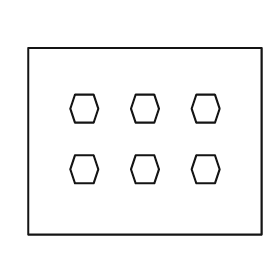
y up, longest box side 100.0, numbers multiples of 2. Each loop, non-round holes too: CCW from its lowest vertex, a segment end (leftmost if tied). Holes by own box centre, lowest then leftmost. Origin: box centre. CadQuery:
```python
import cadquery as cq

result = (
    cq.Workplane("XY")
    .moveTo(-50.0, -40.0)
    .lineTo(50.0, -40.0)
    .lineTo(50.0, 40.0)
    .lineTo(-50.0, 40.0)
    .close()
    .moveTo(-30.0, -18.0)
    .lineTo(-22.0, -18.0)
    .lineTo(-20.0, -12.0)
    .lineTo(-22.0, -6.0)
    .lineTo(-30.0, -6.0)
    .lineTo(-32.0, -12.0)
    .close()
    .moveTo(-4.0, -18.0)
    .lineTo(4.0, -18.0)
    .lineTo(6.0, -12.0)
    .lineTo(4.0, -6.0)
    .lineTo(-4.0, -6.0)
    .lineTo(-6.0, -12.0)
    .close()
    .moveTo(22.0, -18.0)
    .lineTo(30.0, -18.0)
    .lineTo(32.0, -12.0)
    .lineTo(30.0, -6.0)
    .lineTo(22.0, -6.0)
    .lineTo(20.0, -12.0)
    .close()
    .moveTo(-30.0, 8.0)
    .lineTo(-22.0, 8.0)
    .lineTo(-20.0, 14.0)
    .lineTo(-22.0, 20.0)
    .lineTo(-30.0, 20.0)
    .lineTo(-32.0, 14.0)
    .close()
    .moveTo(-4.0, 8.0)
    .lineTo(4.0, 8.0)
    .lineTo(6.0, 14.0)
    .lineTo(4.0, 20.0)
    .lineTo(-4.0, 20.0)
    .lineTo(-6.0, 14.0)
    .close()
    .moveTo(22.0, 8.0)
    .lineTo(30.0, 8.0)
    .lineTo(32.0, 14.0)
    .lineTo(30.0, 20.0)
    .lineTo(22.0, 20.0)
    .lineTo(20.0, 14.0)
    .close()
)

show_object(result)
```